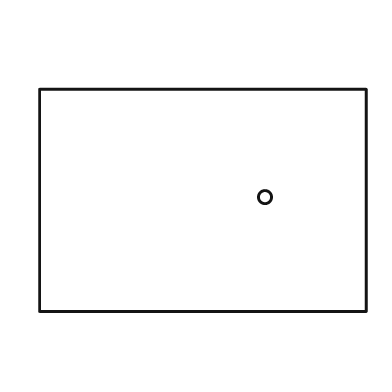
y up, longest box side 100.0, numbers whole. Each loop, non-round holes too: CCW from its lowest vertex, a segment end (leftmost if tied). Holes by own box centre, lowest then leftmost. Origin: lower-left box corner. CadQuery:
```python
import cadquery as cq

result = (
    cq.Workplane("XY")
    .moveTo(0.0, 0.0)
    .lineTo(100.0, 0.0)
    .lineTo(100.0, 68.0)
    .lineTo(0.0, 68.0)
    .close()
    .moveTo(69.0, 35.0)
    .circle(2.0)
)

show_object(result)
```